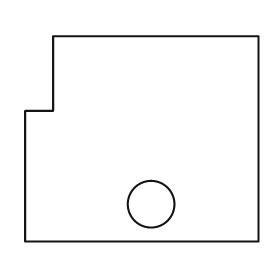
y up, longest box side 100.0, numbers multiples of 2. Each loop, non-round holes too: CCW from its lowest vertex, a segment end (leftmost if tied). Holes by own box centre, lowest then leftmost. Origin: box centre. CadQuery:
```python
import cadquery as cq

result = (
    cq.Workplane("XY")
    .moveTo(-50.0, -44.0)
    .lineTo(50.0, -44.0)
    .lineTo(50.0, 44.0)
    .lineTo(-38.0, 44.0)
    .lineTo(-38.0, 12.0)
    .lineTo(-50.0, 12.0)
    .close()
    .moveTo(4.0, -28.0)
    .circle(10.0)
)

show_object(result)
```